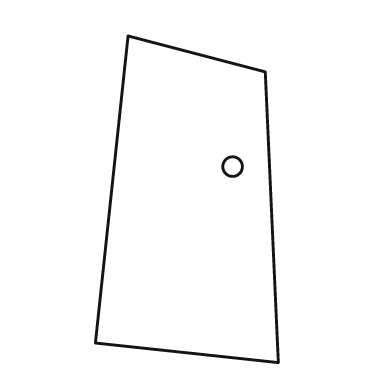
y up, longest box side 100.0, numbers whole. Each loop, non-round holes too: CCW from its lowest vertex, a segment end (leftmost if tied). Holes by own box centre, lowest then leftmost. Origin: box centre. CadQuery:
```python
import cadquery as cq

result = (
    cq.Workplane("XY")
    .moveTo(28.0, -50.0)
    .lineTo(24.0, 39.0)
    .lineTo(-18.0, 50.0)
    .lineTo(-28.0, -44.0)
    .close()
    .moveTo(14.0, 10.0)
    .circle(3.0)
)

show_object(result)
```